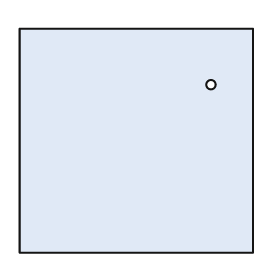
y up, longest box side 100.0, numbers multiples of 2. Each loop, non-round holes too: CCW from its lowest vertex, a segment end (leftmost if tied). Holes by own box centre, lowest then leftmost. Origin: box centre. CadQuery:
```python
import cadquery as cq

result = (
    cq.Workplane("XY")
    .moveTo(-50.0, -48.0)
    .lineTo(50.0, -48.0)
    .lineTo(50.0, 48.0)
    .lineTo(-50.0, 48.0)
    .close()
    .moveTo(32.0, 24.0)
    .circle(2.0)
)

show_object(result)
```